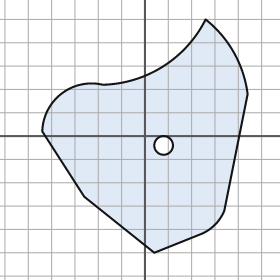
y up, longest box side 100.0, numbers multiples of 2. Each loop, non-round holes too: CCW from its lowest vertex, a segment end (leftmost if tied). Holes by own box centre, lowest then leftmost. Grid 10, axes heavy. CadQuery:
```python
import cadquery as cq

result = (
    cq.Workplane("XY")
    .moveTo(4.0, -50.0)
    .lineTo(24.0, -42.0)
    .threePointArc((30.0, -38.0), (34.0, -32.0))
    .lineTo(44.0, 18.0)
    .threePointArc((38.0, 36.0), (26.0, 50.0))
    .threePointArc((8.0, 30.0), (-18.0, 22.0))
    .threePointArc((-36.0, 18.0), (-44.0, 2.0))
    .lineTo(-26.0, -26.0)
    .close()
    .moveTo(8.0, -4.0)
    .circle(4.0)
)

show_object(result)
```